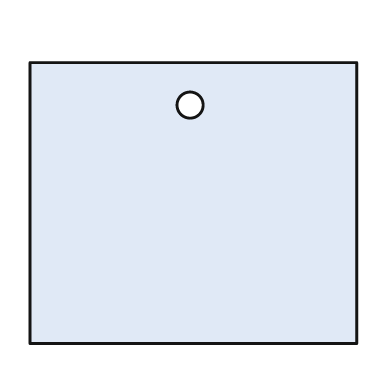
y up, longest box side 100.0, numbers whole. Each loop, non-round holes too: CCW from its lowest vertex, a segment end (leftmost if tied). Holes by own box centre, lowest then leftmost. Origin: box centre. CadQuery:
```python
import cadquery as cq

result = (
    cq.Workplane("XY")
    .moveTo(-50.0, -43.0)
    .lineTo(50.0, -43.0)
    .lineTo(50.0, 43.0)
    .lineTo(-50.0, 43.0)
    .close()
    .moveTo(-1.0, 30.0)
    .circle(4.0)
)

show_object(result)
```